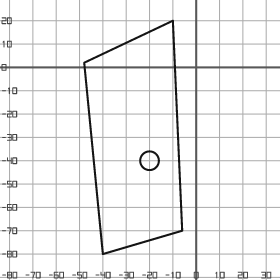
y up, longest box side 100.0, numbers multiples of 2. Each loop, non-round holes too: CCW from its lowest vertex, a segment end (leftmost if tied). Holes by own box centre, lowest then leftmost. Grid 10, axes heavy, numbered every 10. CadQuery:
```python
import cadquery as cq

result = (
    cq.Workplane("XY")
    .moveTo(-40.0, -80.0)
    .lineTo(-6.0, -70.0)
    .lineTo(-10.0, 20.0)
    .lineTo(-48.0, 2.0)
    .close()
    .moveTo(-20.0, -40.0)
    .circle(4.0)
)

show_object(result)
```